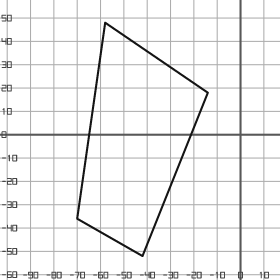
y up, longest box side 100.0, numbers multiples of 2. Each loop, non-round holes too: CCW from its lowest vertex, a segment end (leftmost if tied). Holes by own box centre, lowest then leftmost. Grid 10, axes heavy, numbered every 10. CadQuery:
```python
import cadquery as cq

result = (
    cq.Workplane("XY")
    .moveTo(-42.0, -52.0)
    .lineTo(-14.0, 18.0)
    .lineTo(-58.0, 48.0)
    .lineTo(-70.0, -36.0)
    .close()
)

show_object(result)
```